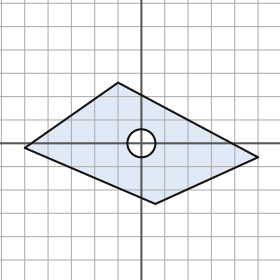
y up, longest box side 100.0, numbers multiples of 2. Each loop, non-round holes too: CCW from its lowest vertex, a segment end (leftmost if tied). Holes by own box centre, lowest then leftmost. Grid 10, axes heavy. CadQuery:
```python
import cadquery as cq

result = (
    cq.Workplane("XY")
    .moveTo(6.0, -26.0)
    .lineTo(50.0, -6.0)
    .lineTo(-10.0, 26.0)
    .lineTo(-50.0, -2.0)
    .close()
    .moveTo(0.0, 0.0)
    .circle(6.0)
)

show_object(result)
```